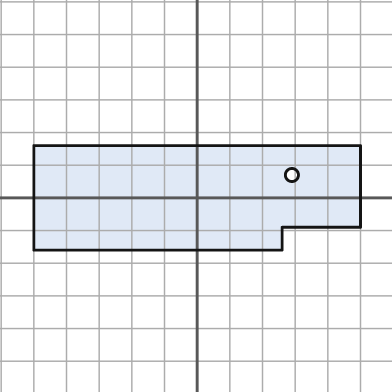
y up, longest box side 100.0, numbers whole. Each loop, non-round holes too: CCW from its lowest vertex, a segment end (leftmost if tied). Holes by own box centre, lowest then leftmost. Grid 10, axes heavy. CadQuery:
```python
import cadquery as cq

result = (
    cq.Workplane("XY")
    .moveTo(-50.0, -16.0)
    .lineTo(26.0, -16.0)
    .lineTo(26.0, -9.0)
    .lineTo(50.0, -9.0)
    .lineTo(50.0, 16.0)
    .lineTo(-50.0, 16.0)
    .close()
    .moveTo(29.0, 7.0)
    .circle(2.0)
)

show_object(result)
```